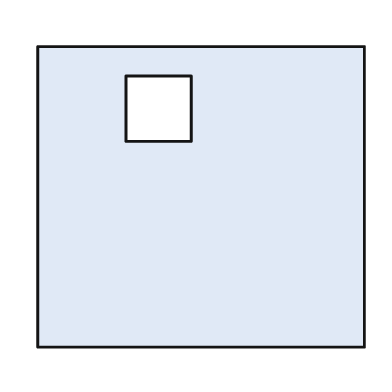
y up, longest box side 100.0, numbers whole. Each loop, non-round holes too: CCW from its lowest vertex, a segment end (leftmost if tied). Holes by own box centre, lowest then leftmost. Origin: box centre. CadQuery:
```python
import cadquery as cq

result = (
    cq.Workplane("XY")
    .moveTo(-50.0, -46.0)
    .lineTo(50.0, -46.0)
    .lineTo(50.0, 46.0)
    .lineTo(-50.0, 46.0)
    .close()
    .moveTo(-23.0, 17.0)
    .lineTo(-3.0, 17.0)
    .lineTo(-3.0, 37.0)
    .lineTo(-23.0, 37.0)
    .close()
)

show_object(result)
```